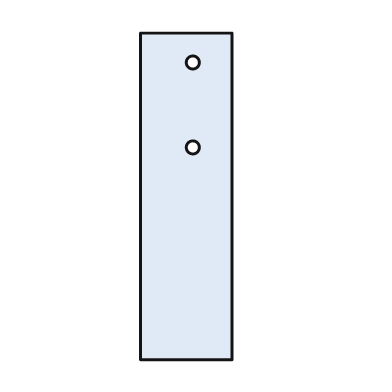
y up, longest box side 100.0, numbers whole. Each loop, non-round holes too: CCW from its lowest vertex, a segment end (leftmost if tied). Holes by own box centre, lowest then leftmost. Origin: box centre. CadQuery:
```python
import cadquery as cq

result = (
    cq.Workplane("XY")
    .moveTo(-14.0, -50.0)
    .lineTo(14.0, -50.0)
    .lineTo(14.0, 50.0)
    .lineTo(-14.0, 50.0)
    .close()
    .moveTo(2.0, 15.0)
    .circle(2.0)
    .moveTo(2.0, 41.0)
    .circle(2.0)
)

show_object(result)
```